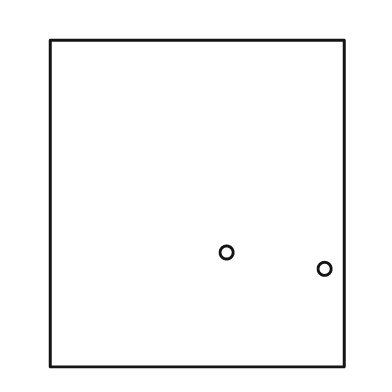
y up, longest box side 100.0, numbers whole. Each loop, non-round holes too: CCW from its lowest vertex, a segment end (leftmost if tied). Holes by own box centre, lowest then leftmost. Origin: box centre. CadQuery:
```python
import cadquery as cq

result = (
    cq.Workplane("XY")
    .moveTo(-45.0, -50.0)
    .lineTo(45.0, -50.0)
    .lineTo(45.0, 50.0)
    .lineTo(-45.0, 50.0)
    .close()
    .moveTo(39.0, -20.0)
    .circle(2.0)
    .moveTo(9.0, -15.0)
    .circle(2.0)
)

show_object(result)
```